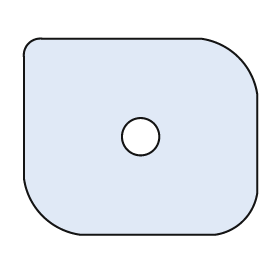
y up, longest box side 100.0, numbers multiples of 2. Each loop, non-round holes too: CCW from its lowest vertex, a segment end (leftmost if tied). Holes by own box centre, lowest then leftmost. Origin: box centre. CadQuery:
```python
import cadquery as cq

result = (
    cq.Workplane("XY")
    .moveTo(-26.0, -42.0)
    .lineTo(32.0, -42.0)
    .threePointArc((44.0, -36.0), (50.0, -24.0))
    .lineTo(50.0, 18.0)
    .threePointArc((42.0, 34.0), (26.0, 42.0))
    .lineTo(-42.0, 42.0)
    .threePointArc((-48.0, 40.0), (-50.0, 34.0))
    .lineTo(-50.0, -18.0)
    .threePointArc((-42.0, -34.0), (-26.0, -42.0))
    .close()
    .moveTo(0.0, 0.0)
    .circle(8.0)
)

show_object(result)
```